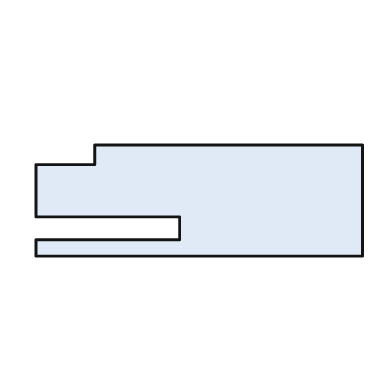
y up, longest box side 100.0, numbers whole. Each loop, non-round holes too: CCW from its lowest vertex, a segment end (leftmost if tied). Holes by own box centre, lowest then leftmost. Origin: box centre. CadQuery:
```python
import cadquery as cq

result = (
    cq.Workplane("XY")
    .moveTo(-50.0, -17.0)
    .lineTo(50.0, -17.0)
    .lineTo(50.0, 17.0)
    .lineTo(-32.0, 17.0)
    .lineTo(-32.0, 11.0)
    .lineTo(-50.0, 11.0)
    .lineTo(-50.0, -5.0)
    .lineTo(-6.0, -5.0)
    .lineTo(-6.0, -12.0)
    .lineTo(-50.0, -12.0)
    .close()
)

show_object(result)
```